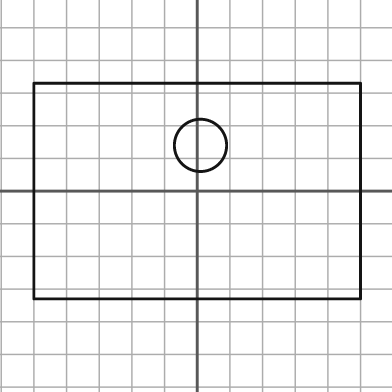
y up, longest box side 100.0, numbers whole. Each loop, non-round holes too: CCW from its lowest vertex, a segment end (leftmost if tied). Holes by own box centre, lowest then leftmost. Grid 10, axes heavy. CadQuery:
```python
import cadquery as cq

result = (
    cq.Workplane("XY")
    .moveTo(-50.0, -33.0)
    .lineTo(50.0, -33.0)
    .lineTo(50.0, 33.0)
    .lineTo(-50.0, 33.0)
    .close()
    .moveTo(1.0, 14.0)
    .circle(8.0)
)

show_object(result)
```